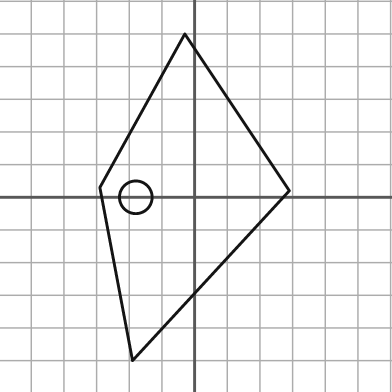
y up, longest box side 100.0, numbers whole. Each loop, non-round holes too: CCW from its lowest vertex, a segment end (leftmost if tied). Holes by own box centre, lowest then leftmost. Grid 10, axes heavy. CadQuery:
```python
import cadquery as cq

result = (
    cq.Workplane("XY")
    .moveTo(-19.0, -50.0)
    .lineTo(29.0, 2.0)
    .lineTo(-3.0, 50.0)
    .lineTo(-29.0, 3.0)
    .close()
    .moveTo(-18.0, 0.0)
    .circle(5.0)
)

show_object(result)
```